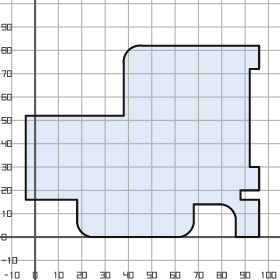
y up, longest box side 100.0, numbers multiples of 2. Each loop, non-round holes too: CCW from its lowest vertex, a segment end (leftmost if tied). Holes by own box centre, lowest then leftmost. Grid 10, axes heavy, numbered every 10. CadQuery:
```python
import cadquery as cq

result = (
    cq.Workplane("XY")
    .moveTo(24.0, 0.0)
    .lineTo(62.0, 0.0)
    .threePointArc((66.0, 2.0), (68.0, 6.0))
    .lineTo(68.0, 14.0)
    .lineTo(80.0, 14.0)
    .threePointArc((84.0, 12.0), (86.0, 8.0))
    .lineTo(86.0, 0.0)
    .lineTo(96.0, 0.0)
    .lineTo(96.0, 16.0)
    .lineTo(88.0, 16.0)
    .lineTo(88.0, 20.0)
    .lineTo(96.0, 20.0)
    .lineTo(96.0, 30.0)
    .lineTo(92.0, 30.0)
    .lineTo(92.0, 72.0)
    .lineTo(96.0, 72.0)
    .lineTo(96.0, 82.0)
    .lineTo(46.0, 82.0)
    .threePointArc((40.0, 80.0), (38.0, 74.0))
    .lineTo(38.0, 52.0)
    .lineTo(-4.0, 52.0)
    .lineTo(-4.0, 16.0)
    .lineTo(18.0, 16.0)
    .lineTo(18.0, 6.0)
    .threePointArc((20.0, 2.0), (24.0, 0.0))
    .close()
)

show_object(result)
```